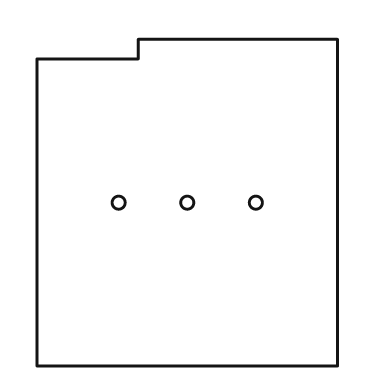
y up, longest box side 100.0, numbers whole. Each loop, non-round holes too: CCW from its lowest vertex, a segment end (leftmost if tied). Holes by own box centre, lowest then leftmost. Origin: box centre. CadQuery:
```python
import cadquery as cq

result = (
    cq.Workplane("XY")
    .moveTo(-46.0, -50.0)
    .lineTo(46.0, -50.0)
    .lineTo(46.0, 50.0)
    .lineTo(-15.0, 50.0)
    .lineTo(-15.0, 44.0)
    .lineTo(-46.0, 44.0)
    .close()
    .moveTo(-21.0, 0.0)
    .circle(2.0)
    .moveTo(0.0, 0.0)
    .circle(2.0)
    .moveTo(21.0, 0.0)
    .circle(2.0)
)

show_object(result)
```